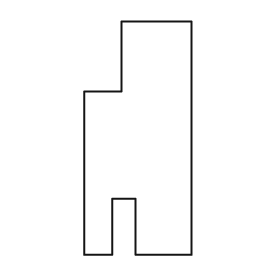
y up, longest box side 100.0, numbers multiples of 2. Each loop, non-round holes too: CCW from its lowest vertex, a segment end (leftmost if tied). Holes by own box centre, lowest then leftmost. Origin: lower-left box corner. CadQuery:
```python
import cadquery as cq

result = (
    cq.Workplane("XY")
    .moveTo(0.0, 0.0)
    .lineTo(12.0, 0.0)
    .lineTo(12.0, 24.0)
    .lineTo(22.0, 24.0)
    .lineTo(22.0, 0.0)
    .lineTo(46.0, 0.0)
    .lineTo(46.0, 100.0)
    .lineTo(16.0, 100.0)
    .lineTo(16.0, 70.0)
    .lineTo(0.0, 70.0)
    .close()
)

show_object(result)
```